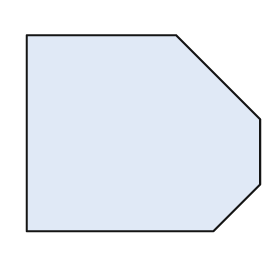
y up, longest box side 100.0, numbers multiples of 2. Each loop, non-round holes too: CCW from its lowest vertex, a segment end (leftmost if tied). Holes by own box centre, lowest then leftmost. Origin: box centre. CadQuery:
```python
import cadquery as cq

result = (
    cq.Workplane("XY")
    .moveTo(-50.0, -42.0)
    .lineTo(30.0, -42.0)
    .lineTo(50.0, -22.0)
    .lineTo(50.0, 6.0)
    .lineTo(14.0, 42.0)
    .lineTo(-50.0, 42.0)
    .close()
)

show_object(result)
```